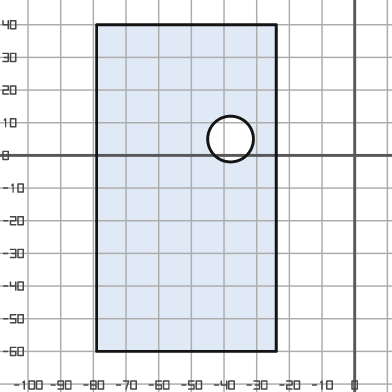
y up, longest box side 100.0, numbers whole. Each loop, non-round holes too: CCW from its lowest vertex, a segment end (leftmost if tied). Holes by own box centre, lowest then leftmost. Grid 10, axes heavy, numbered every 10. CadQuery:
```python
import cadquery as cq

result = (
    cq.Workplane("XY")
    .moveTo(-79.0, -60.0)
    .lineTo(-24.0, -60.0)
    .lineTo(-24.0, 40.0)
    .lineTo(-79.0, 40.0)
    .close()
    .moveTo(-38.0, 5.0)
    .circle(7.0)
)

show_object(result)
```